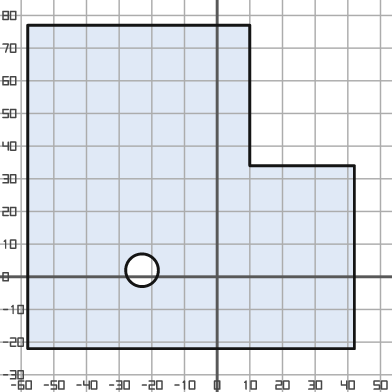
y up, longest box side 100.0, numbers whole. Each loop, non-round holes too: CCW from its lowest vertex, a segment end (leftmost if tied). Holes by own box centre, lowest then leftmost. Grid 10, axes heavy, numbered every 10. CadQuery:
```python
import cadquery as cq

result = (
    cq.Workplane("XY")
    .moveTo(-58.0, -22.0)
    .lineTo(42.0, -22.0)
    .lineTo(42.0, 34.0)
    .lineTo(10.0, 34.0)
    .lineTo(10.0, 77.0)
    .lineTo(-58.0, 77.0)
    .close()
    .moveTo(-23.0, 2.0)
    .circle(5.0)
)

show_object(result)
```